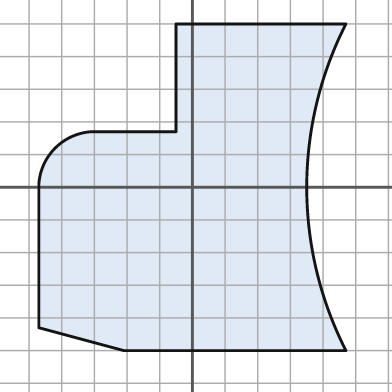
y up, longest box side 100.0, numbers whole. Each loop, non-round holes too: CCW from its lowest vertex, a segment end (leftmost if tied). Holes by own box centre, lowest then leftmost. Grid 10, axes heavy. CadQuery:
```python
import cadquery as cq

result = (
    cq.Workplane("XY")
    .moveTo(-21.0, -50.0)
    .lineTo(47.0, -50.0)
    .threePointArc((35.0, 0.0), (47.0, 50.0))
    .lineTo(-5.0, 50.0)
    .lineTo(-5.0, 17.0)
    .lineTo(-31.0, 17.0)
    .threePointArc((-42.0, 12.0), (-47.0, 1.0))
    .lineTo(-47.0, -43.0)
    .close()
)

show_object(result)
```